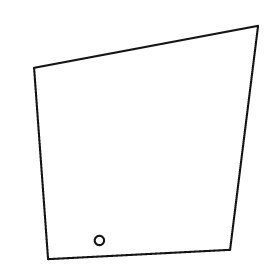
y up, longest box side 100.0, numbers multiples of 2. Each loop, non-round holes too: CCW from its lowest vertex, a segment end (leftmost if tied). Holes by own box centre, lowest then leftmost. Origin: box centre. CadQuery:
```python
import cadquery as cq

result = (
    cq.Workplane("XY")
    .moveTo(-42.0, -50.0)
    .lineTo(36.0, -46.0)
    .lineTo(48.0, 50.0)
    .lineTo(-48.0, 32.0)
    .close()
    .moveTo(-20.0, -42.0)
    .circle(2.0)
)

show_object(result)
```